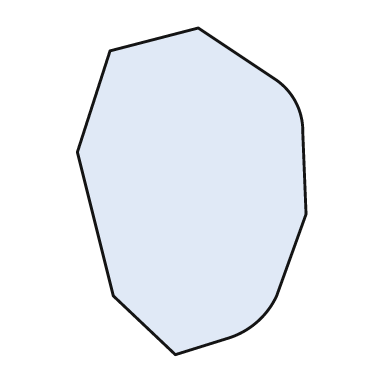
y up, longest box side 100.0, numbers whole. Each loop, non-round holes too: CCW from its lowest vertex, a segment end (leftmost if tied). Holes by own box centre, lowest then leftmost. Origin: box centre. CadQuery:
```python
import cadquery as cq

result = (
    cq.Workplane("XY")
    .moveTo(-5.0, -50.0)
    .lineTo(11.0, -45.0)
    .threePointArc((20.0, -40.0), (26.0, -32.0))
    .lineTo(35.0, -7.0)
    .lineTo(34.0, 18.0)
    .threePointArc((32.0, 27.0), (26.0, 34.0))
    .lineTo(2.0, 50.0)
    .lineTo(-25.0, 43.0)
    .lineTo(-35.0, 12.0)
    .lineTo(-24.0, -32.0)
    .close()
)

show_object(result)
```